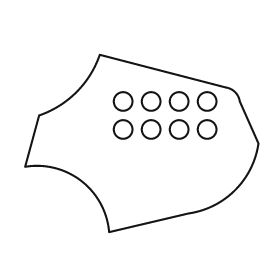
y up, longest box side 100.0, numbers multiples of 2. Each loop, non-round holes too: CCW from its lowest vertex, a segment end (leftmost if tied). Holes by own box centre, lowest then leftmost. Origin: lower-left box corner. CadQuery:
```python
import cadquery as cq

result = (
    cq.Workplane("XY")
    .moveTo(36.0, 0.0)
    .lineTo(70.0, 8.0)
    .threePointArc((90.0, 18.0), (100.0, 38.0))
    .lineTo(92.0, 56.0)
    .threePointArc((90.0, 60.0), (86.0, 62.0))
    .lineTo(32.0, 76.0)
    .threePointArc((22.0, 60.0), (6.0, 50.0))
    .lineTo(0.0, 28.0)
    .threePointArc((24.0, 22.0), (36.0, 0.0))
    .close()
    .moveTo(42.0, 44.0)
    .circle(4.0)
    .moveTo(54.0, 44.0)
    .circle(4.0)
    .moveTo(66.0, 44.0)
    .circle(4.0)
    .moveTo(78.0, 44.0)
    .circle(4.0)
    .moveTo(42.0, 56.0)
    .circle(4.0)
    .moveTo(54.0, 56.0)
    .circle(4.0)
    .moveTo(66.0, 56.0)
    .circle(4.0)
    .moveTo(78.0, 56.0)
    .circle(4.0)
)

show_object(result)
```